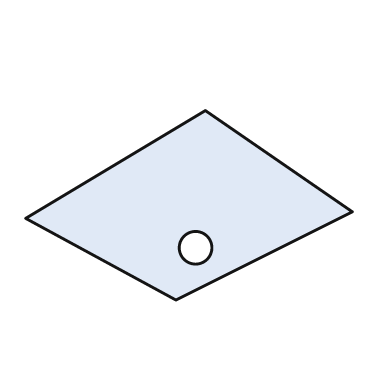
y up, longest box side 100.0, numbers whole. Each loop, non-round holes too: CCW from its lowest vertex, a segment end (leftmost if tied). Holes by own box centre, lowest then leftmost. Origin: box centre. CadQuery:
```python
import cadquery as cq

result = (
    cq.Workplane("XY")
    .moveTo(-4.0, -29.0)
    .lineTo(50.0, -2.0)
    .lineTo(5.0, 29.0)
    .lineTo(-50.0, -4.0)
    .close()
    .moveTo(2.0, -13.0)
    .circle(5.0)
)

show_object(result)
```